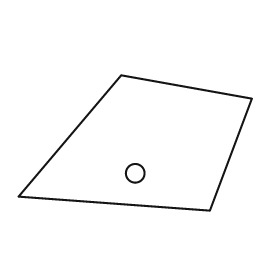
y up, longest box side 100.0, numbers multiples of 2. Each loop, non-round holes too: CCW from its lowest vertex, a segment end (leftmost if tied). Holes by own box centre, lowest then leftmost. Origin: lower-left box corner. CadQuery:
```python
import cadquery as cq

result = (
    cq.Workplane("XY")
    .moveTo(82.0, 0.0)
    .lineTo(100.0, 48.0)
    .lineTo(44.0, 58.0)
    .lineTo(0.0, 6.0)
    .close()
    .moveTo(50.0, 16.0)
    .circle(4.0)
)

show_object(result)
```